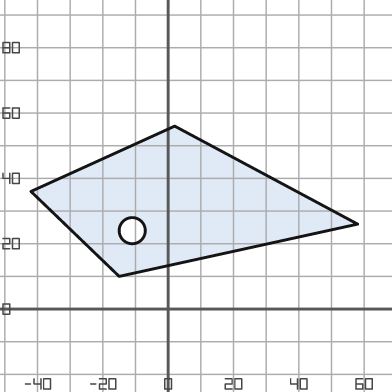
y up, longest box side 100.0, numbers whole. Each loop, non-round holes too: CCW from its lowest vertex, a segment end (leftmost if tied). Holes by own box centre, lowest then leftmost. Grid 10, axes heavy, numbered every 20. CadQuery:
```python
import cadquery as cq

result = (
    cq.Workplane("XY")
    .moveTo(-15.0, 10.0)
    .lineTo(58.0, 26.0)
    .lineTo(2.0, 56.0)
    .lineTo(-42.0, 36.0)
    .close()
    .moveTo(-11.0, 24.0)
    .circle(4.0)
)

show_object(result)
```